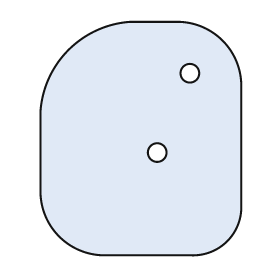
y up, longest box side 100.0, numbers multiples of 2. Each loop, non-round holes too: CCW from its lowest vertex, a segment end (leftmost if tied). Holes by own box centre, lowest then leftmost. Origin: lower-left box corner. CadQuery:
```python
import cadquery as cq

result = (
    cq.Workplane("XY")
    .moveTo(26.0, 0.0)
    .lineTo(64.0, 0.0)
    .threePointArc((80.0, 6.0), (86.0, 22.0))
    .lineTo(86.0, 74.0)
    .threePointArc((78.0, 92.0), (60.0, 100.0))
    .lineTo(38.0, 100.0)
    .threePointArc((12.0, 88.0), (0.0, 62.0))
    .lineTo(0.0, 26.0)
    .threePointArc((8.0, 8.0), (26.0, 0.0))
    .close()
    .moveTo(50.0, 44.0)
    .circle(4.0)
    .moveTo(64.0, 78.0)
    .circle(4.0)
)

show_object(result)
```